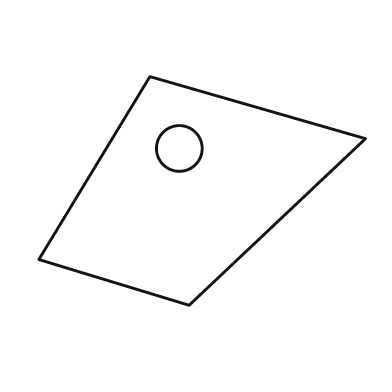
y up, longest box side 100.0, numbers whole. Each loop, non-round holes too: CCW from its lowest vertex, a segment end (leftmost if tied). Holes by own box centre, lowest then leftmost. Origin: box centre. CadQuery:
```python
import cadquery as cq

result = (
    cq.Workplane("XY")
    .moveTo(-4.0, -35.0)
    .lineTo(50.0, 16.0)
    .lineTo(-16.0, 35.0)
    .lineTo(-50.0, -21.0)
    .close()
    .moveTo(-7.0, 13.0)
    .circle(7.0)
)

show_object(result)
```